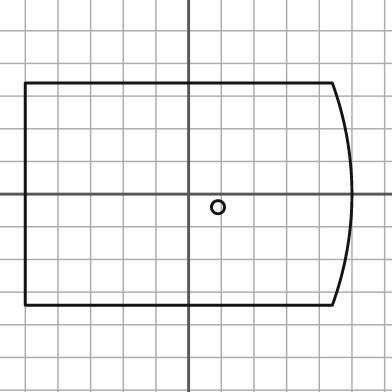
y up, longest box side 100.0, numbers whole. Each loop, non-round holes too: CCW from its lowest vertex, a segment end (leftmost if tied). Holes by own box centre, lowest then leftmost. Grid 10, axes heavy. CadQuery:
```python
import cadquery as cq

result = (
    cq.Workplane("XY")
    .moveTo(-50.0, -34.0)
    .lineTo(44.0, -34.0)
    .threePointArc((50.0, 0.0), (44.0, 34.0))
    .lineTo(-50.0, 34.0)
    .close()
    .moveTo(9.0, -4.0)
    .circle(2.0)
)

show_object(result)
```